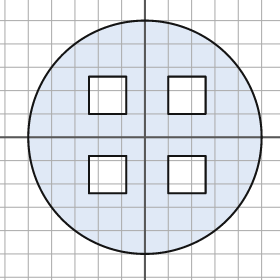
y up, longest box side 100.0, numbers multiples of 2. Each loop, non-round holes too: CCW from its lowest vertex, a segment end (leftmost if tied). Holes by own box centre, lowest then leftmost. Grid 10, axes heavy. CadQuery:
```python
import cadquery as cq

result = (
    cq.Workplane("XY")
    .moveTo(0.0, 0.0)
    .circle(50.0)
    .moveTo(-24.0, -24.0)
    .lineTo(-8.0, -24.0)
    .lineTo(-8.0, -8.0)
    .lineTo(-24.0, -8.0)
    .close()
    .moveTo(10.0, -24.0)
    .lineTo(26.0, -24.0)
    .lineTo(26.0, -8.0)
    .lineTo(10.0, -8.0)
    .close()
    .moveTo(-24.0, 10.0)
    .lineTo(-8.0, 10.0)
    .lineTo(-8.0, 26.0)
    .lineTo(-24.0, 26.0)
    .close()
    .moveTo(10.0, 10.0)
    .lineTo(26.0, 10.0)
    .lineTo(26.0, 26.0)
    .lineTo(10.0, 26.0)
    .close()
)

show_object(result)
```